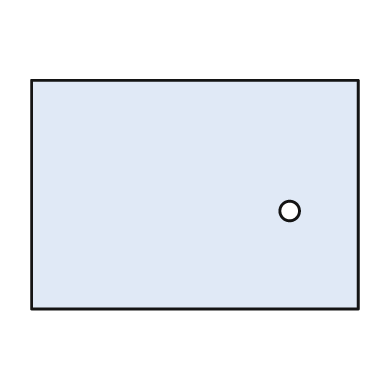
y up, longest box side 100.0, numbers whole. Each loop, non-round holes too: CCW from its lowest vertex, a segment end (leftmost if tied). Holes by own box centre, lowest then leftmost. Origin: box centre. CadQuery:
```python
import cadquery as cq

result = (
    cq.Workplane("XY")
    .moveTo(-50.0, -35.0)
    .lineTo(50.0, -35.0)
    .lineTo(50.0, 35.0)
    .lineTo(-50.0, 35.0)
    .close()
    .moveTo(29.0, -5.0)
    .circle(3.0)
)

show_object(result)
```